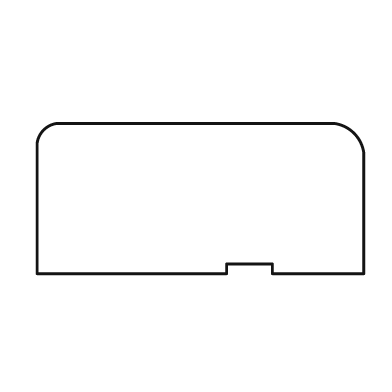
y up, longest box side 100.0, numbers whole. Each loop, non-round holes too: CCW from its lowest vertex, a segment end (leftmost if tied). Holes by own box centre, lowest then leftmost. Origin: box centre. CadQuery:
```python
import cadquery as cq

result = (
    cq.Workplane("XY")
    .moveTo(-50.0, -23.0)
    .lineTo(8.0, -23.0)
    .lineTo(8.0, -20.0)
    .lineTo(22.0, -20.0)
    .lineTo(22.0, -23.0)
    .lineTo(50.0, -23.0)
    .lineTo(50.0, 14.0)
    .threePointArc((47.0, 20.0), (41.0, 23.0))
    .lineTo(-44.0, 23.0)
    .threePointArc((-48.0, 21.0), (-50.0, 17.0))
    .close()
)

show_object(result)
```